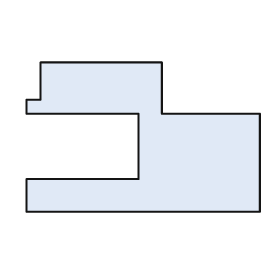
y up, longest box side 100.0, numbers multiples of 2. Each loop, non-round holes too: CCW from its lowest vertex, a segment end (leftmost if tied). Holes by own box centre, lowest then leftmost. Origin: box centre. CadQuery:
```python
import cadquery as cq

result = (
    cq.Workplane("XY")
    .moveTo(-50.0, -32.0)
    .lineTo(50.0, -32.0)
    .lineTo(50.0, 10.0)
    .lineTo(8.0, 10.0)
    .lineTo(8.0, 32.0)
    .lineTo(-44.0, 32.0)
    .lineTo(-44.0, 16.0)
    .lineTo(-50.0, 16.0)
    .lineTo(-50.0, 10.0)
    .lineTo(-2.0, 10.0)
    .lineTo(-2.0, -18.0)
    .lineTo(-50.0, -18.0)
    .close()
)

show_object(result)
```